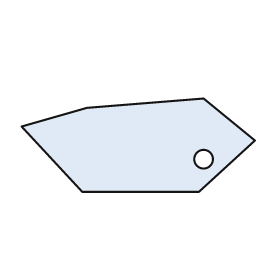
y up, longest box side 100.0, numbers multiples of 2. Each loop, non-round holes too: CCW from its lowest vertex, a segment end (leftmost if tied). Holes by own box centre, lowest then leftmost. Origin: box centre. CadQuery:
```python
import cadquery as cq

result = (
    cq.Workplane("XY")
    .moveTo(-24.0, -20.0)
    .lineTo(26.0, -20.0)
    .lineTo(50.0, 2.0)
    .lineTo(28.0, 20.0)
    .lineTo(-22.0, 16.0)
    .lineTo(-50.0, 8.0)
    .close()
    .moveTo(28.0, -6.0)
    .circle(4.0)
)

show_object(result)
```